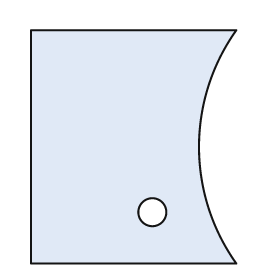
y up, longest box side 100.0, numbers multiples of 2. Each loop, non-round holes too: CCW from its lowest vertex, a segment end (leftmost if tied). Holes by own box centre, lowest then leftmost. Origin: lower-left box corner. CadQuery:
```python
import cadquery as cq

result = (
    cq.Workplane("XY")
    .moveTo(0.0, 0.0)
    .lineTo(88.0, 0.0)
    .threePointArc((72.0, 50.0), (88.0, 100.0))
    .lineTo(0.0, 100.0)
    .close()
    .moveTo(52.0, 22.0)
    .circle(6.0)
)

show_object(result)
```